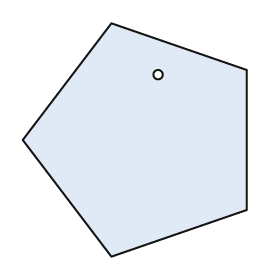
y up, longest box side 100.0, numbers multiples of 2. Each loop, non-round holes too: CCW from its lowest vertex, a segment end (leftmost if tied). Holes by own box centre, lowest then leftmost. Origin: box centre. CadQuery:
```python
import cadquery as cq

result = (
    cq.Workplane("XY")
    .moveTo(-10.0, -50.0)
    .lineTo(48.0, -30.0)
    .lineTo(48.0, 30.0)
    .lineTo(-10.0, 50.0)
    .lineTo(-48.0, 0.0)
    .close()
    .moveTo(10.0, 28.0)
    .circle(2.0)
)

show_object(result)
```